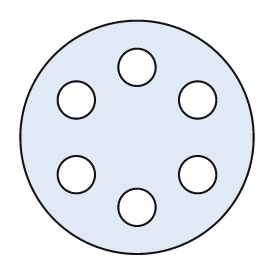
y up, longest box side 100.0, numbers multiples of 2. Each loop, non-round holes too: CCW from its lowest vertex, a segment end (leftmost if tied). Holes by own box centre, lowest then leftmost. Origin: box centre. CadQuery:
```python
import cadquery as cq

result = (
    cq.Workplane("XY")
    .moveTo(0.0, 0.0)
    .circle(50.0)
    .moveTo(0.0, -30.0)
    .circle(8.0)
    .moveTo(-26.0, -16.0)
    .circle(8.0)
    .moveTo(26.0, -16.0)
    .circle(8.0)
    .moveTo(-26.0, 16.0)
    .circle(8.0)
    .moveTo(26.0, 16.0)
    .circle(8.0)
    .moveTo(0.0, 30.0)
    .circle(8.0)
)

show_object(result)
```